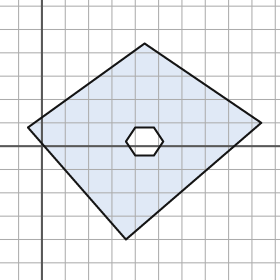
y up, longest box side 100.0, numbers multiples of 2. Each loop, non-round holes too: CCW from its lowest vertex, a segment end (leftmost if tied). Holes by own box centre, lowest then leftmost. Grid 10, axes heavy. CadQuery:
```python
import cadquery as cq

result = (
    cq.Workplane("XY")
    .moveTo(36.0, -40.0)
    .lineTo(94.0, 10.0)
    .lineTo(44.0, 44.0)
    .lineTo(-6.0, 8.0)
    .close()
    .moveTo(40.0, -4.0)
    .lineTo(48.0, -4.0)
    .lineTo(52.0, 2.0)
    .lineTo(48.0, 8.0)
    .lineTo(40.0, 8.0)
    .lineTo(36.0, 2.0)
    .close()
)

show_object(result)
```